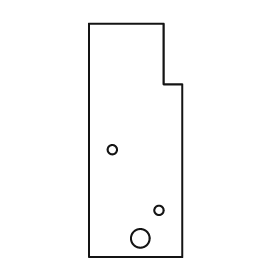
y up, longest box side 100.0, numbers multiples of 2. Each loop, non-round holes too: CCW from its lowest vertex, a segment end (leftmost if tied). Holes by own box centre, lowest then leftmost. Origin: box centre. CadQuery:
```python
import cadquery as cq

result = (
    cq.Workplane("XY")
    .moveTo(-20.0, -50.0)
    .lineTo(20.0, -50.0)
    .lineTo(20.0, 24.0)
    .lineTo(12.0, 24.0)
    .lineTo(12.0, 50.0)
    .lineTo(-20.0, 50.0)
    .close()
    .moveTo(2.0, -42.0)
    .circle(4.0)
    .moveTo(10.0, -30.0)
    .circle(2.0)
    .moveTo(-10.0, -4.0)
    .circle(2.0)
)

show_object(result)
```